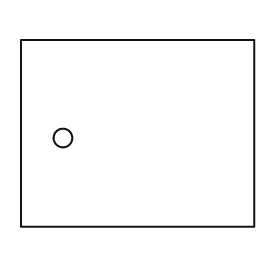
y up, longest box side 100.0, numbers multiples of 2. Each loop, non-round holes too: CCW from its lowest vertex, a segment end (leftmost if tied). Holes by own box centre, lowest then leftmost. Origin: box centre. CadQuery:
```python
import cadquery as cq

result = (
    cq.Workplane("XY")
    .moveTo(-50.0, -40.0)
    .lineTo(50.0, -40.0)
    .lineTo(50.0, 40.0)
    .lineTo(-50.0, 40.0)
    .close()
    .moveTo(-32.0, -2.0)
    .circle(4.0)
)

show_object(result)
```